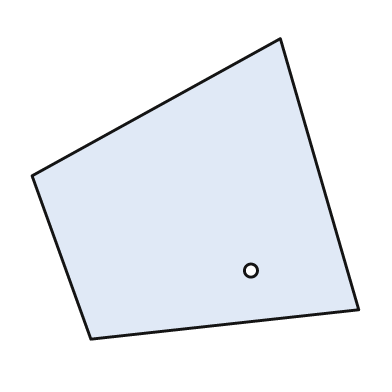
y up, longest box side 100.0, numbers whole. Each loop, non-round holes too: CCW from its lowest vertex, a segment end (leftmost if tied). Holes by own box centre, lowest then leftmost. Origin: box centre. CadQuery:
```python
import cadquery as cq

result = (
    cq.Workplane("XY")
    .moveTo(-32.0, -46.0)
    .lineTo(50.0, -37.0)
    .lineTo(26.0, 46.0)
    .lineTo(-50.0, 4.0)
    .close()
    .moveTo(17.0, -25.0)
    .circle(2.0)
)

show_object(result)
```